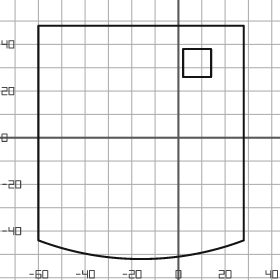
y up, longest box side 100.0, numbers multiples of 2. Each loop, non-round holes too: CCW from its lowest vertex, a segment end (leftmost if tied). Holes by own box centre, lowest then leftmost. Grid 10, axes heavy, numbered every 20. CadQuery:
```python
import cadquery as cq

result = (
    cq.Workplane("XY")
    .moveTo(-60.0, -44.0)
    .threePointArc((-16.0, -52.0), (28.0, -44.0))
    .lineTo(28.0, 48.0)
    .lineTo(-60.0, 48.0)
    .close()
    .moveTo(2.0, 26.0)
    .lineTo(14.0, 26.0)
    .lineTo(14.0, 38.0)
    .lineTo(2.0, 38.0)
    .close()
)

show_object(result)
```